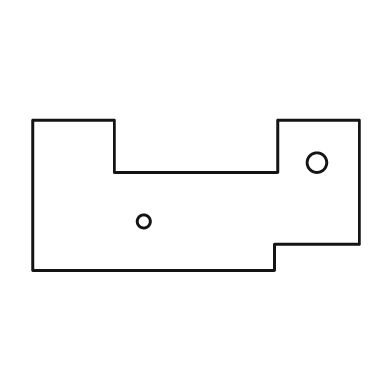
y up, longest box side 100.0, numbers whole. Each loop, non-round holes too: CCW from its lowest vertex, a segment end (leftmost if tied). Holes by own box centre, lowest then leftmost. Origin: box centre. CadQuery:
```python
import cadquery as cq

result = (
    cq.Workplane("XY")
    .moveTo(-50.0, -23.0)
    .lineTo(24.0, -23.0)
    .lineTo(24.0, -15.0)
    .lineTo(50.0, -15.0)
    .lineTo(50.0, 23.0)
    .lineTo(25.0, 23.0)
    .lineTo(25.0, 7.0)
    .lineTo(-25.0, 7.0)
    .lineTo(-25.0, 23.0)
    .lineTo(-50.0, 23.0)
    .close()
    .moveTo(-16.0, -8.0)
    .circle(2.0)
    .moveTo(37.0, 10.0)
    .circle(3.0)
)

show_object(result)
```